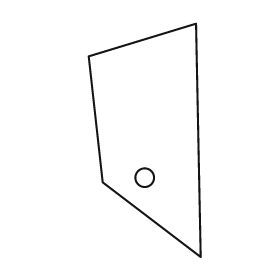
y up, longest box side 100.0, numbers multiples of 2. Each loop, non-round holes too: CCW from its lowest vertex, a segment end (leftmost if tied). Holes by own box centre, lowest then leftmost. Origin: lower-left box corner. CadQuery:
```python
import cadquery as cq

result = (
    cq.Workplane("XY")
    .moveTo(48.0, 0.0)
    .lineTo(46.0, 100.0)
    .lineTo(0.0, 86.0)
    .lineTo(6.0, 32.0)
    .close()
    .moveTo(24.0, 34.0)
    .circle(4.0)
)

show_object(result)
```